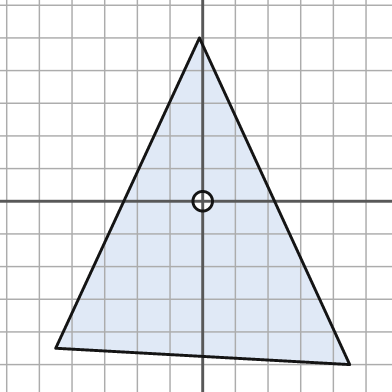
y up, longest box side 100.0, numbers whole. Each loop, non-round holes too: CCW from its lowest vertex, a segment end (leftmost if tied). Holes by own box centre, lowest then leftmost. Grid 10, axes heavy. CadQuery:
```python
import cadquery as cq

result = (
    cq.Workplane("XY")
    .moveTo(45.0, -50.0)
    .lineTo(-1.0, 50.0)
    .lineTo(-45.0, -45.0)
    .close()
    .moveTo(0.0, 0.0)
    .circle(3.0)
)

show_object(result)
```